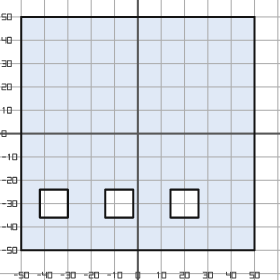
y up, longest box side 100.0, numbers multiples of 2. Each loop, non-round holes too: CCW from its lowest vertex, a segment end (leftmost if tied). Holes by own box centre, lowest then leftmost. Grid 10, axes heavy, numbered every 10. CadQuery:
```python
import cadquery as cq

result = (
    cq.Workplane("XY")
    .moveTo(-50.0, -50.0)
    .lineTo(50.0, -50.0)
    .lineTo(50.0, 50.0)
    .lineTo(-50.0, 50.0)
    .close()
    .moveTo(-42.0, -36.0)
    .lineTo(-30.0, -36.0)
    .lineTo(-30.0, -24.0)
    .lineTo(-42.0, -24.0)
    .close()
    .moveTo(-14.0, -36.0)
    .lineTo(-2.0, -36.0)
    .lineTo(-2.0, -24.0)
    .lineTo(-14.0, -24.0)
    .close()
    .moveTo(14.0, -36.0)
    .lineTo(26.0, -36.0)
    .lineTo(26.0, -24.0)
    .lineTo(14.0, -24.0)
    .close()
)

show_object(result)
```